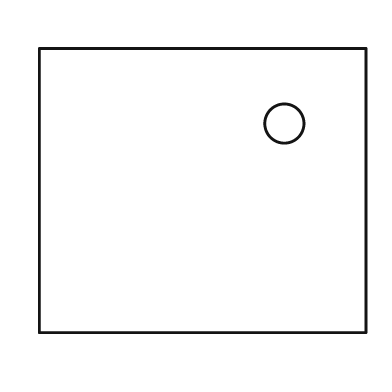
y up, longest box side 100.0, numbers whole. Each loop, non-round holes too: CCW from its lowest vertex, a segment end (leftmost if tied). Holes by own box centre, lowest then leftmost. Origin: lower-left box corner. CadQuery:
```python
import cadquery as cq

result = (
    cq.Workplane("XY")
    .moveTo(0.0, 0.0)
    .lineTo(100.0, 0.0)
    .lineTo(100.0, 87.0)
    .lineTo(0.0, 87.0)
    .close()
    .moveTo(75.0, 64.0)
    .circle(6.0)
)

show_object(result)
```